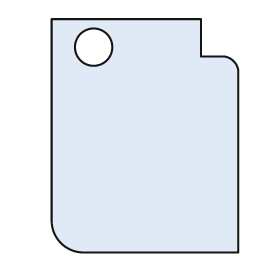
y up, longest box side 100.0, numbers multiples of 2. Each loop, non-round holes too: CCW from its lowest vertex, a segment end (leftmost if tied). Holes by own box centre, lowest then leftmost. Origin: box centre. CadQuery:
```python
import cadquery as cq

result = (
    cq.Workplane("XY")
    .moveTo(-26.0, -50.0)
    .lineTo(40.0, -50.0)
    .lineTo(40.0, 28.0)
    .threePointArc((38.0, 32.0), (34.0, 34.0))
    .lineTo(24.0, 34.0)
    .lineTo(24.0, 50.0)
    .lineTo(-40.0, 50.0)
    .lineTo(-40.0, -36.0)
    .threePointArc((-36.0, -46.0), (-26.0, -50.0))
    .close()
    .moveTo(-22.0, 38.0)
    .circle(8.0)
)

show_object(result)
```